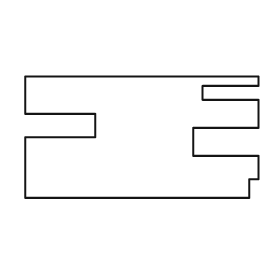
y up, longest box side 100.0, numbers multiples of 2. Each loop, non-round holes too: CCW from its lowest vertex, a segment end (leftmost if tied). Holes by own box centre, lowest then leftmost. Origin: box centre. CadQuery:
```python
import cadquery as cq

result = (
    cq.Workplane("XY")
    .moveTo(-50.0, -26.0)
    .lineTo(46.0, -26.0)
    .lineTo(46.0, -18.0)
    .lineTo(50.0, -18.0)
    .lineTo(50.0, -8.0)
    .lineTo(22.0, -8.0)
    .lineTo(22.0, 4.0)
    .lineTo(50.0, 4.0)
    .lineTo(50.0, 16.0)
    .lineTo(26.0, 16.0)
    .lineTo(26.0, 22.0)
    .lineTo(50.0, 22.0)
    .lineTo(50.0, 26.0)
    .lineTo(-50.0, 26.0)
    .lineTo(-50.0, 10.0)
    .lineTo(-20.0, 10.0)
    .lineTo(-20.0, 0.0)
    .lineTo(-50.0, 0.0)
    .close()
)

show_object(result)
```